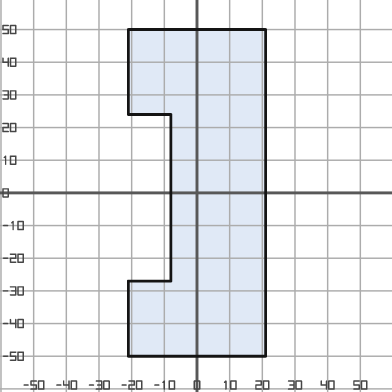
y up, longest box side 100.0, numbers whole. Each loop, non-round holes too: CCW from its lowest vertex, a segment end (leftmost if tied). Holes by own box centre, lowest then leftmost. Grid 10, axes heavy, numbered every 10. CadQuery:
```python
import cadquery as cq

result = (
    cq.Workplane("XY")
    .moveTo(-21.0, -50.0)
    .lineTo(21.0, -50.0)
    .lineTo(21.0, 50.0)
    .lineTo(-21.0, 50.0)
    .lineTo(-21.0, 24.0)
    .lineTo(-8.0, 24.0)
    .lineTo(-8.0, -27.0)
    .lineTo(-21.0, -27.0)
    .close()
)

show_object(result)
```